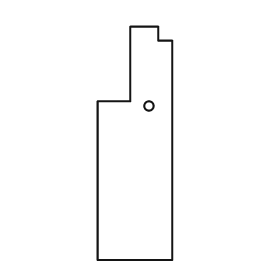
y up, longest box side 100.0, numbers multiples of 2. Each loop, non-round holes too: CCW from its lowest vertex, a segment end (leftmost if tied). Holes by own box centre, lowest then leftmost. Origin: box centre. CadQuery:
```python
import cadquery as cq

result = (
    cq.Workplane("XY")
    .moveTo(-16.0, -50.0)
    .lineTo(16.0, -50.0)
    .lineTo(16.0, 44.0)
    .lineTo(10.0, 44.0)
    .lineTo(10.0, 50.0)
    .lineTo(-2.0, 50.0)
    .lineTo(-2.0, 18.0)
    .lineTo(-16.0, 18.0)
    .close()
    .moveTo(6.0, 16.0)
    .circle(2.0)
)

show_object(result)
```